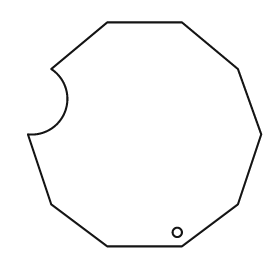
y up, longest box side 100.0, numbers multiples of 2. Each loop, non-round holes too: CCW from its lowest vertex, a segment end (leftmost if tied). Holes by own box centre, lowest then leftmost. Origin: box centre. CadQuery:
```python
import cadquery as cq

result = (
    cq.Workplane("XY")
    .moveTo(-16.0, -48.0)
    .lineTo(16.0, -48.0)
    .lineTo(40.0, -30.0)
    .lineTo(50.0, 0.0)
    .lineTo(40.0, 28.0)
    .lineTo(16.0, 48.0)
    .lineTo(-16.0, 48.0)
    .lineTo(-40.0, 28.0)
    .threePointArc((-34.0, 10.0), (-50.0, 0.0))
    .lineTo(-40.0, -30.0)
    .close()
    .moveTo(14.0, -42.0)
    .circle(2.0)
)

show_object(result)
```